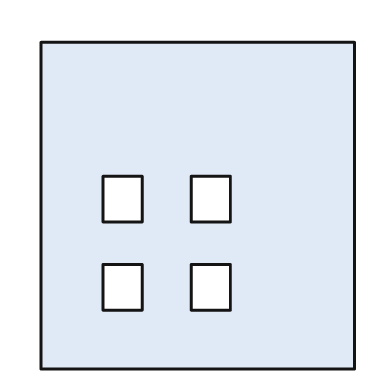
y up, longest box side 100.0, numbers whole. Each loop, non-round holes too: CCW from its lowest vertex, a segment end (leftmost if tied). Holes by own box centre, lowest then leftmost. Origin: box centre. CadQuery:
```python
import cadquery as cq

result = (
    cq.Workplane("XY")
    .moveTo(-48.0, -50.0)
    .lineTo(48.0, -50.0)
    .lineTo(48.0, 50.0)
    .lineTo(-48.0, 50.0)
    .close()
    .moveTo(-29.0, -32.0)
    .lineTo(-17.0, -32.0)
    .lineTo(-17.0, -18.0)
    .lineTo(-29.0, -18.0)
    .close()
    .moveTo(-2.0, -32.0)
    .lineTo(10.0, -32.0)
    .lineTo(10.0, -18.0)
    .lineTo(-2.0, -18.0)
    .close()
    .moveTo(-29.0, -5.0)
    .lineTo(-17.0, -5.0)
    .lineTo(-17.0, 9.0)
    .lineTo(-29.0, 9.0)
    .close()
    .moveTo(-2.0, -5.0)
    .lineTo(10.0, -5.0)
    .lineTo(10.0, 9.0)
    .lineTo(-2.0, 9.0)
    .close()
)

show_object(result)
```